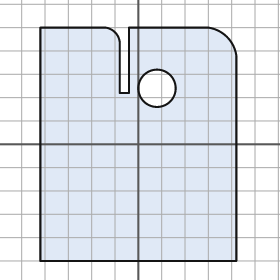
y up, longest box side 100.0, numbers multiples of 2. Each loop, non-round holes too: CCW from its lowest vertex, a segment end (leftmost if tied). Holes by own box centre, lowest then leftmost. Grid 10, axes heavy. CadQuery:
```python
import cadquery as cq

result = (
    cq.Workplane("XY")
    .moveTo(-42.0, -50.0)
    .lineTo(42.0, -50.0)
    .lineTo(42.0, 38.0)
    .threePointArc((38.0, 46.0), (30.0, 50.0))
    .lineTo(-4.0, 50.0)
    .lineTo(-4.0, 22.0)
    .lineTo(-8.0, 22.0)
    .lineTo(-8.0, 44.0)
    .threePointArc((-10.0, 48.0), (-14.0, 50.0))
    .lineTo(-42.0, 50.0)
    .close()
    .moveTo(8.0, 24.0)
    .circle(8.0)
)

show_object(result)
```